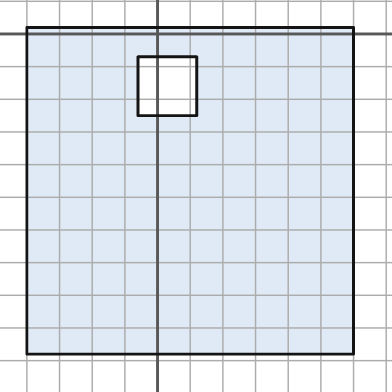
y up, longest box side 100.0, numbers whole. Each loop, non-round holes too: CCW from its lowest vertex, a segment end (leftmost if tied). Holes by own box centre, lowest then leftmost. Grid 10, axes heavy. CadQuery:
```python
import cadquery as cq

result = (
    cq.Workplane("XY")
    .moveTo(-40.0, -98.0)
    .lineTo(60.0, -98.0)
    .lineTo(60.0, 2.0)
    .lineTo(-40.0, 2.0)
    .close()
    .moveTo(-6.0, -25.0)
    .lineTo(12.0, -25.0)
    .lineTo(12.0, -7.0)
    .lineTo(-6.0, -7.0)
    .close()
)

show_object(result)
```